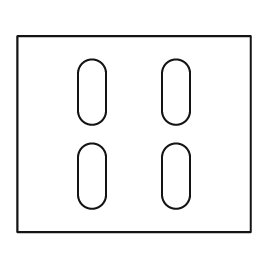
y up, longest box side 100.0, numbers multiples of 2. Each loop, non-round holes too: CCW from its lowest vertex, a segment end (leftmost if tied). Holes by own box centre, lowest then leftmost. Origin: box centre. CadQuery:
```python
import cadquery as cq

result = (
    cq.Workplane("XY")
    .moveTo(-50.0, -42.0)
    .lineTo(50.0, -42.0)
    .lineTo(50.0, 42.0)
    .lineTo(-50.0, 42.0)
    .close()
    .moveTo(-24.0, -26.0)
    .threePointArc((-18.0, -32.0), (-12.0, -26.0))
    .lineTo(-12.0, -10.0)
    .threePointArc((-18.0, -4.0), (-24.0, -10.0))
    .close()
    .moveTo(12.0, -26.0)
    .threePointArc((18.0, -32.0), (24.0, -26.0))
    .lineTo(24.0, -10.0)
    .threePointArc((18.0, -4.0), (12.0, -10.0))
    .close()
    .moveTo(-24.0, 10.0)
    .threePointArc((-18.0, 4.0), (-12.0, 10.0))
    .lineTo(-12.0, 26.0)
    .threePointArc((-18.0, 32.0), (-24.0, 26.0))
    .close()
    .moveTo(12.0, 10.0)
    .threePointArc((18.0, 4.0), (24.0, 10.0))
    .lineTo(24.0, 26.0)
    .threePointArc((18.0, 32.0), (12.0, 26.0))
    .close()
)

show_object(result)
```